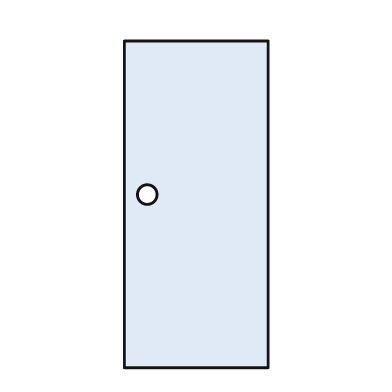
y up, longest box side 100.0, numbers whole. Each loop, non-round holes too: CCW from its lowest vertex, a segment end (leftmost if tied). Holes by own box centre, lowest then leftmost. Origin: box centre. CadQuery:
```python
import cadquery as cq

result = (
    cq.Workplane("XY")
    .moveTo(-22.0, -50.0)
    .lineTo(22.0, -50.0)
    .lineTo(22.0, 50.0)
    .lineTo(-22.0, 50.0)
    .close()
    .moveTo(-15.0, 3.0)
    .circle(3.0)
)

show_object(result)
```